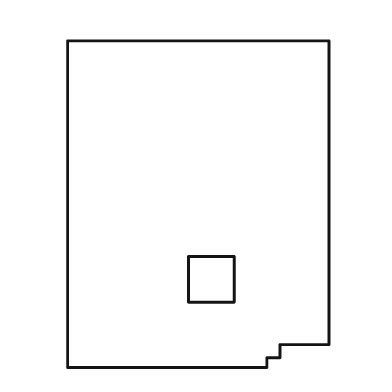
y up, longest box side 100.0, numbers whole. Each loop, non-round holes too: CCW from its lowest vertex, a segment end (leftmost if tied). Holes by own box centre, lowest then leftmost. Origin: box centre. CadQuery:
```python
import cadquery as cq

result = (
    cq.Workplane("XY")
    .moveTo(-40.0, -50.0)
    .lineTo(21.0, -50.0)
    .lineTo(21.0, -47.0)
    .lineTo(25.0, -47.0)
    .lineTo(25.0, -43.0)
    .lineTo(40.0, -43.0)
    .lineTo(40.0, 50.0)
    .lineTo(-40.0, 50.0)
    .close()
    .moveTo(-3.0, -30.0)
    .lineTo(11.0, -30.0)
    .lineTo(11.0, -16.0)
    .lineTo(-3.0, -16.0)
    .close()
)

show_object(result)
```